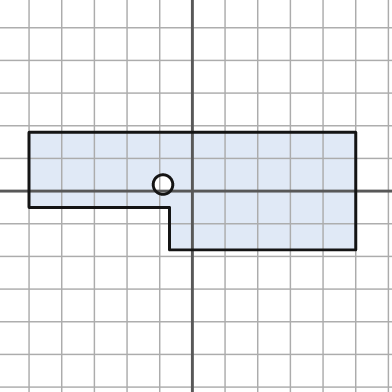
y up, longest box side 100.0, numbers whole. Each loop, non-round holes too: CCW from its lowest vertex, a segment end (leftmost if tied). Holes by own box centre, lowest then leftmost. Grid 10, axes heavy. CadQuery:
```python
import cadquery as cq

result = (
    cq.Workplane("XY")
    .moveTo(-7.0, -18.0)
    .lineTo(50.0, -18.0)
    .lineTo(50.0, 18.0)
    .lineTo(-50.0, 18.0)
    .lineTo(-50.0, -5.0)
    .lineTo(-7.0, -5.0)
    .close()
    .moveTo(-9.0, 2.0)
    .circle(3.0)
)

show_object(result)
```